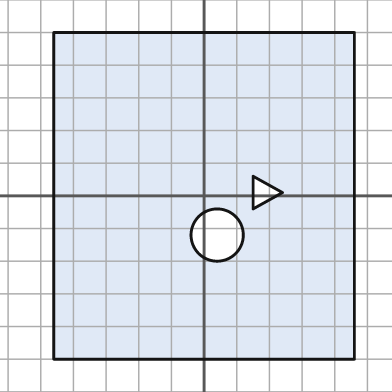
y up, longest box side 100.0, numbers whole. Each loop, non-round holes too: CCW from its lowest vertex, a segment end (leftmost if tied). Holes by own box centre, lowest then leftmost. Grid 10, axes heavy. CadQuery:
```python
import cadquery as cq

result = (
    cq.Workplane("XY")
    .moveTo(-46.0, -50.0)
    .lineTo(46.0, -50.0)
    .lineTo(46.0, 50.0)
    .lineTo(-46.0, 50.0)
    .close()
    .moveTo(4.0, -12.0)
    .circle(8.0)
    .moveTo(15.0, -4.0)
    .lineTo(24.0, 1.0)
    .lineTo(15.0, 6.0)
    .close()
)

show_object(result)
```